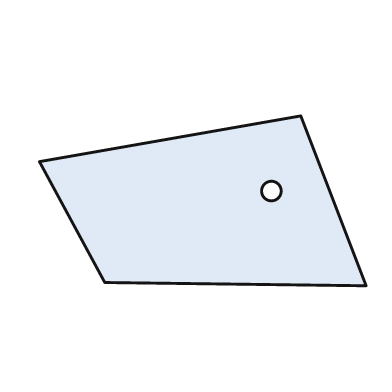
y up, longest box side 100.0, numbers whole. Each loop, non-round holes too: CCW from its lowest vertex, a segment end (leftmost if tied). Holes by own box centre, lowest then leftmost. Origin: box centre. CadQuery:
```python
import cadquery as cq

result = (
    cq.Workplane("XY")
    .moveTo(50.0, -26.0)
    .lineTo(30.0, 26.0)
    .lineTo(-50.0, 12.0)
    .lineTo(-30.0, -25.0)
    .close()
    .moveTo(21.0, 3.0)
    .circle(3.0)
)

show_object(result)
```